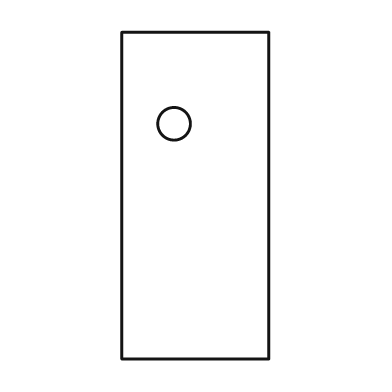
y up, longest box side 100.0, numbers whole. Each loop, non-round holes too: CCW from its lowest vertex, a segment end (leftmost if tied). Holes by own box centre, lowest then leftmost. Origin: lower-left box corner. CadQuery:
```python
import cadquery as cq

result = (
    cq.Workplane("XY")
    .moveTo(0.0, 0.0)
    .lineTo(45.0, 0.0)
    .lineTo(45.0, 100.0)
    .lineTo(0.0, 100.0)
    .close()
    .moveTo(16.0, 72.0)
    .circle(5.0)
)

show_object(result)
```